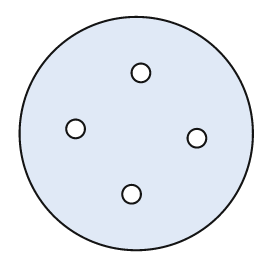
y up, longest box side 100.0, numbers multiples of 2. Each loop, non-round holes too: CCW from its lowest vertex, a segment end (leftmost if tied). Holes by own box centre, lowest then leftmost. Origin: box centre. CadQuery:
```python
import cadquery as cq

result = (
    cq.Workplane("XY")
    .moveTo(0.0, 0.0)
    .circle(50.0)
    .moveTo(-2.0, -26.0)
    .circle(4.0)
    .moveTo(26.0, -2.0)
    .circle(4.0)
    .moveTo(-26.0, 2.0)
    .circle(4.0)
    .moveTo(2.0, 26.0)
    .circle(4.0)
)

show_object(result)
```